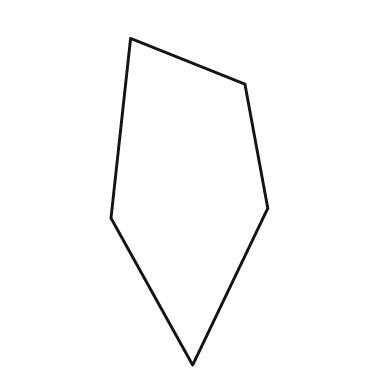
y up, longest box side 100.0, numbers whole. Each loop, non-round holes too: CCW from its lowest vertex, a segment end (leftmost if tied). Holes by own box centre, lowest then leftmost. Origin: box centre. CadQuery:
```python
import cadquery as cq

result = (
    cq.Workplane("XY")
    .moveTo(1.0, -50.0)
    .lineTo(24.0, -2.0)
    .lineTo(17.0, 36.0)
    .lineTo(-18.0, 50.0)
    .lineTo(-24.0, -5.0)
    .close()
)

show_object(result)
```